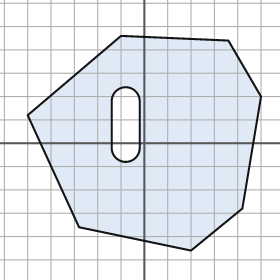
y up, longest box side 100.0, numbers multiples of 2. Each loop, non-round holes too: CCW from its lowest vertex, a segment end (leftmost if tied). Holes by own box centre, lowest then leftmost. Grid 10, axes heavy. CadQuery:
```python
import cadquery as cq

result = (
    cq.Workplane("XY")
    .moveTo(20.0, -46.0)
    .lineTo(42.0, -28.0)
    .lineTo(50.0, 20.0)
    .lineTo(36.0, 44.0)
    .lineTo(-10.0, 46.0)
    .lineTo(-50.0, 12.0)
    .lineTo(-28.0, -36.0)
    .close()
    .moveTo(-14.0, -2.0)
    .threePointArc((-8.0, -8.0), (-2.0, -2.0))
    .lineTo(-2.0, 18.0)
    .threePointArc((-8.0, 24.0), (-14.0, 18.0))
    .close()
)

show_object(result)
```